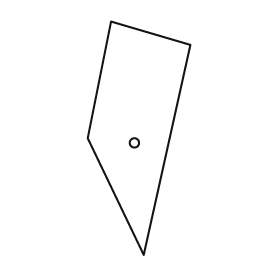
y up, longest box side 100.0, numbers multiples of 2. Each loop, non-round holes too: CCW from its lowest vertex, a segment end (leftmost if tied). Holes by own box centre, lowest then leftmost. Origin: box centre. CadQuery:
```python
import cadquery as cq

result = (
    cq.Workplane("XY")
    .moveTo(2.0, -50.0)
    .lineTo(22.0, 40.0)
    .lineTo(-12.0, 50.0)
    .lineTo(-22.0, 0.0)
    .close()
    .moveTo(-2.0, -2.0)
    .circle(2.0)
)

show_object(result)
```